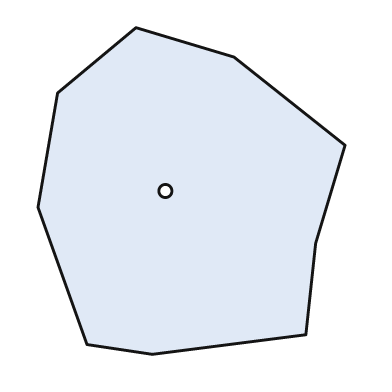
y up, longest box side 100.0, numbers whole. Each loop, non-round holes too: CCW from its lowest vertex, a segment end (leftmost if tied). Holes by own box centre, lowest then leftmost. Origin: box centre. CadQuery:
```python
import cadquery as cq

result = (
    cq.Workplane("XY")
    .moveTo(-12.0, -50.0)
    .lineTo(35.0, -44.0)
    .lineTo(38.0, -16.0)
    .lineTo(47.0, 14.0)
    .lineTo(13.0, 41.0)
    .lineTo(-17.0, 50.0)
    .lineTo(-41.0, 30.0)
    .lineTo(-47.0, -5.0)
    .lineTo(-32.0, -47.0)
    .close()
    .moveTo(-8.0, 0.0)
    .circle(2.0)
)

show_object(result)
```